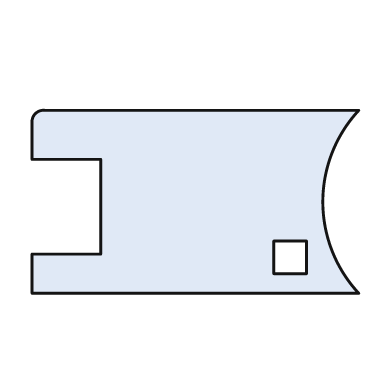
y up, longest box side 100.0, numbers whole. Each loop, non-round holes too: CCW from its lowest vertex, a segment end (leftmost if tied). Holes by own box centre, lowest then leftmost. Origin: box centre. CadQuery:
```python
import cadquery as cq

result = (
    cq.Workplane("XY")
    .moveTo(-50.0, -28.0)
    .lineTo(50.0, -28.0)
    .threePointArc((39.0, 0.0), (50.0, 28.0))
    .lineTo(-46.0, 28.0)
    .threePointArc((-49.0, 27.0), (-50.0, 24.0))
    .lineTo(-50.0, 13.0)
    .lineTo(-29.0, 13.0)
    .lineTo(-29.0, -16.0)
    .lineTo(-50.0, -16.0)
    .close()
    .moveTo(24.0, -22.0)
    .lineTo(34.0, -22.0)
    .lineTo(34.0, -12.0)
    .lineTo(24.0, -12.0)
    .close()
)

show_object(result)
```